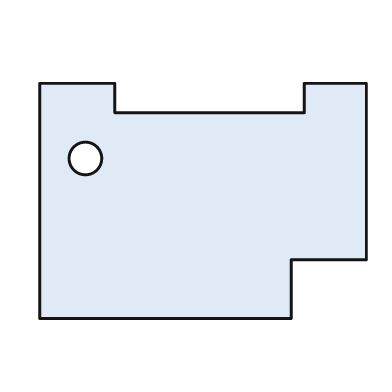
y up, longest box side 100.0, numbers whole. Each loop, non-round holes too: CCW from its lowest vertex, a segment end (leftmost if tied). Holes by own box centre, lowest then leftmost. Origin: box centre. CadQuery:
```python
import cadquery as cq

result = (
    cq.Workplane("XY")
    .moveTo(-50.0, -36.0)
    .lineTo(27.0, -36.0)
    .lineTo(27.0, -18.0)
    .lineTo(50.0, -18.0)
    .lineTo(50.0, 36.0)
    .lineTo(31.0, 36.0)
    .lineTo(31.0, 27.0)
    .lineTo(-27.0, 27.0)
    .lineTo(-27.0, 36.0)
    .lineTo(-50.0, 36.0)
    .close()
    .moveTo(-36.0, 13.0)
    .circle(5.0)
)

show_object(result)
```